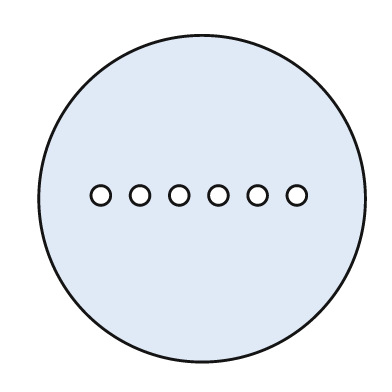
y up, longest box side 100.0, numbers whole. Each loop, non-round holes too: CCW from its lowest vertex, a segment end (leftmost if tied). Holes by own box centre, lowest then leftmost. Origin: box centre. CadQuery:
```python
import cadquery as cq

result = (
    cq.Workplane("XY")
    .moveTo(0.0, 0.0)
    .circle(50.0)
    .moveTo(-31.0, 1.0)
    .circle(3.0)
    .moveTo(-19.0, 1.0)
    .circle(3.0)
    .moveTo(-7.0, 1.0)
    .circle(3.0)
    .moveTo(5.0, 1.0)
    .circle(3.0)
    .moveTo(17.0, 1.0)
    .circle(3.0)
    .moveTo(29.0, 1.0)
    .circle(3.0)
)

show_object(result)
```